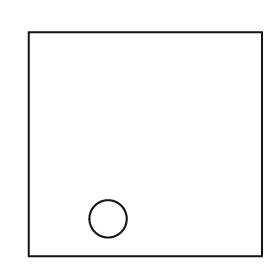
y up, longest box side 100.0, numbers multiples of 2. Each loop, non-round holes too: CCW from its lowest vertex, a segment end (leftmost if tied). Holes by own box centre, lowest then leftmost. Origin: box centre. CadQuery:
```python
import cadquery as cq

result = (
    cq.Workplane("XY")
    .moveTo(-50.0, -48.0)
    .lineTo(50.0, -48.0)
    .lineTo(50.0, 48.0)
    .lineTo(-50.0, 48.0)
    .close()
    .moveTo(-16.0, -32.0)
    .circle(8.0)
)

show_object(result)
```